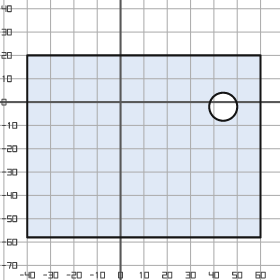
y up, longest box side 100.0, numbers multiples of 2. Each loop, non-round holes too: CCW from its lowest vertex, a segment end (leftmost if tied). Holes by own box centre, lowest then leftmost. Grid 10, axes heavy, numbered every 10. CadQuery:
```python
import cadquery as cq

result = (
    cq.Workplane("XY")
    .moveTo(-40.0, -58.0)
    .lineTo(60.0, -58.0)
    .lineTo(60.0, 20.0)
    .lineTo(-40.0, 20.0)
    .close()
    .moveTo(44.0, -2.0)
    .circle(6.0)
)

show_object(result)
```